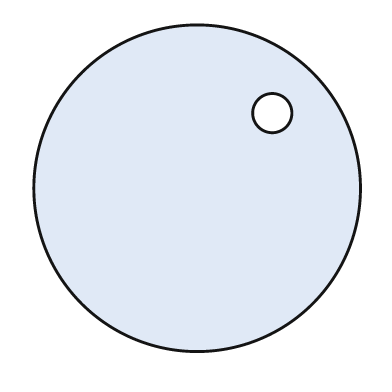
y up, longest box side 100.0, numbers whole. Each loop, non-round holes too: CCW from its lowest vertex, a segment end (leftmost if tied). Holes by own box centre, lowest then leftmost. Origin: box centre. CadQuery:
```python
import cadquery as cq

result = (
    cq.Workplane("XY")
    .moveTo(0.0, 0.0)
    .circle(50.0)
    .moveTo(23.0, 23.0)
    .circle(6.0)
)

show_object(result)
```